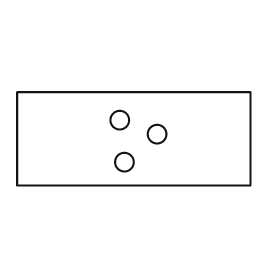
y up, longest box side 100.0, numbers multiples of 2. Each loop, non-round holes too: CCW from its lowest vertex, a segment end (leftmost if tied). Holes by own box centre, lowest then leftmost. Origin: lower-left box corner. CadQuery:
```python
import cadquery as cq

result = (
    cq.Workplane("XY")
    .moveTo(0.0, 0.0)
    .lineTo(100.0, 0.0)
    .lineTo(100.0, 40.0)
    .lineTo(0.0, 40.0)
    .close()
    .moveTo(46.0, 10.0)
    .circle(4.0)
    .moveTo(60.0, 22.0)
    .circle(4.0)
    .moveTo(44.0, 28.0)
    .circle(4.0)
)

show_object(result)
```